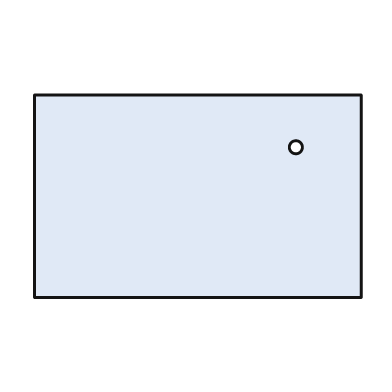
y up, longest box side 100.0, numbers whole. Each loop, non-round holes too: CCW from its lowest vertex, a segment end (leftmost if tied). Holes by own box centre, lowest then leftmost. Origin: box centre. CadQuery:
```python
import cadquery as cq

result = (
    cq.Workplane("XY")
    .moveTo(-50.0, -31.0)
    .lineTo(50.0, -31.0)
    .lineTo(50.0, 31.0)
    .lineTo(-50.0, 31.0)
    .close()
    .moveTo(30.0, 15.0)
    .circle(2.0)
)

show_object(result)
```